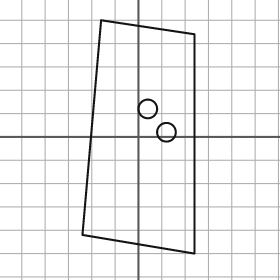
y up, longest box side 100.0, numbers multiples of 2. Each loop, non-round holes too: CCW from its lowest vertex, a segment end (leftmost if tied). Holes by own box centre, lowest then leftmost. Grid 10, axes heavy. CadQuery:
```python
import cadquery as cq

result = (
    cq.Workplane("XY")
    .moveTo(24.0, -50.0)
    .lineTo(24.0, 44.0)
    .lineTo(-16.0, 50.0)
    .lineTo(-24.0, -42.0)
    .close()
    .moveTo(12.0, 2.0)
    .circle(4.0)
    .moveTo(4.0, 12.0)
    .circle(4.0)
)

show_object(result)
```